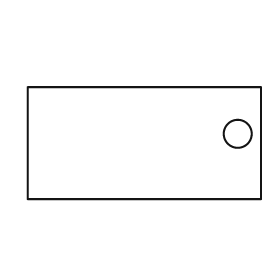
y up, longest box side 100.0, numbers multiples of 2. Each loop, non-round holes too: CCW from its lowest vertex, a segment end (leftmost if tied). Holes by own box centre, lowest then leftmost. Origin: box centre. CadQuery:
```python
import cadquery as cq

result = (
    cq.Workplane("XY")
    .moveTo(-50.0, -24.0)
    .lineTo(50.0, -24.0)
    .lineTo(50.0, 24.0)
    .lineTo(-50.0, 24.0)
    .close()
    .moveTo(40.0, 4.0)
    .circle(6.0)
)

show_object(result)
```